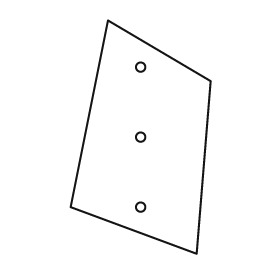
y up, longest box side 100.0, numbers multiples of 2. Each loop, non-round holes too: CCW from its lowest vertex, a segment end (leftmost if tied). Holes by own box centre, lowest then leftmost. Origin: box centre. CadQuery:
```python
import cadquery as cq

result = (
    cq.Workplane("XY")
    .moveTo(24.0, -50.0)
    .lineTo(30.0, 24.0)
    .lineTo(-14.0, 50.0)
    .lineTo(-30.0, -30.0)
    .close()
    .moveTo(0.0, -30.0)
    .circle(2.0)
    .moveTo(0.0, 0.0)
    .circle(2.0)
    .moveTo(0.0, 30.0)
    .circle(2.0)
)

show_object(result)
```